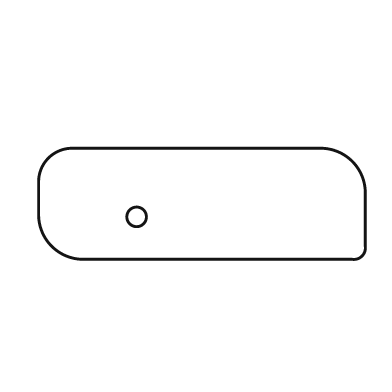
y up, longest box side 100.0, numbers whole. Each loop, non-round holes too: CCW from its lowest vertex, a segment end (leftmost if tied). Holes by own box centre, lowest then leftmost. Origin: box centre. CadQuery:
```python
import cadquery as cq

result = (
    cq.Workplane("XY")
    .moveTo(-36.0, -17.0)
    .lineTo(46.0, -17.0)
    .threePointArc((49.0, -16.0), (50.0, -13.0))
    .lineTo(50.0, 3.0)
    .threePointArc((46.0, 13.0), (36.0, 17.0))
    .lineTo(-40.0, 17.0)
    .threePointArc((-47.0, 14.0), (-50.0, 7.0))
    .lineTo(-50.0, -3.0)
    .threePointArc((-46.0, -13.0), (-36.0, -17.0))
    .close()
    .moveTo(-20.0, -4.0)
    .circle(3.0)
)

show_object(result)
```